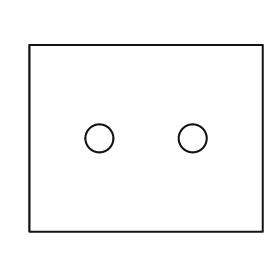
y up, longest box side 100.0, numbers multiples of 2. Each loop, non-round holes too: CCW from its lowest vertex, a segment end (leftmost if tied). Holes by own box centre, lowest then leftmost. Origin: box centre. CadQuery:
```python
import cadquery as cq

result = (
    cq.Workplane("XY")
    .moveTo(-50.0, -40.0)
    .lineTo(50.0, -40.0)
    .lineTo(50.0, 40.0)
    .lineTo(-50.0, 40.0)
    .close()
    .moveTo(-20.0, 0.0)
    .circle(6.0)
    .moveTo(20.0, 0.0)
    .circle(6.0)
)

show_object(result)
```